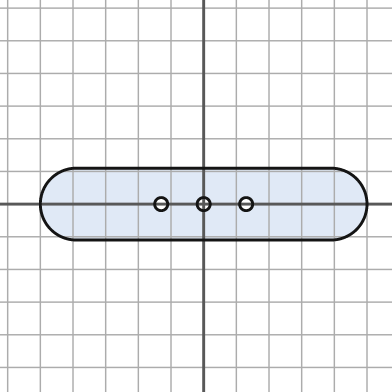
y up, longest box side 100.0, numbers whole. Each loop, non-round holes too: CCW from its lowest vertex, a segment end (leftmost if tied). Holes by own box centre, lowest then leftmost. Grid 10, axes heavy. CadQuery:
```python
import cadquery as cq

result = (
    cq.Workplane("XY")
    .moveTo(-39.0, -11.0)
    .lineTo(39.0, -11.0)
    .threePointArc((50.0, 0.0), (39.0, 11.0))
    .lineTo(-39.0, 11.0)
    .threePointArc((-50.0, 0.0), (-39.0, -11.0))
    .close()
    .moveTo(-13.0, 0.0)
    .circle(2.0)
    .moveTo(0.0, 0.0)
    .circle(2.0)
    .moveTo(13.0, 0.0)
    .circle(2.0)
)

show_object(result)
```